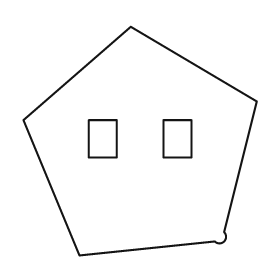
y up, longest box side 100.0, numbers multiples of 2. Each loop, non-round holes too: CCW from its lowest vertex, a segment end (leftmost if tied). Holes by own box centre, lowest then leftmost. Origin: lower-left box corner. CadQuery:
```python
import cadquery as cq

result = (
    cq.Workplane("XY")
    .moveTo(24.0, 0.0)
    .lineTo(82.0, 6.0)
    .threePointArc((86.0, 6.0), (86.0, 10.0))
    .lineTo(100.0, 66.0)
    .lineTo(46.0, 98.0)
    .lineTo(0.0, 58.0)
    .close()
    .moveTo(28.0, 42.0)
    .lineTo(40.0, 42.0)
    .lineTo(40.0, 58.0)
    .lineTo(28.0, 58.0)
    .close()
    .moveTo(60.0, 42.0)
    .lineTo(72.0, 42.0)
    .lineTo(72.0, 58.0)
    .lineTo(60.0, 58.0)
    .close()
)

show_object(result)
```